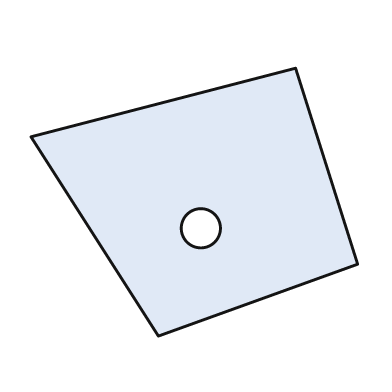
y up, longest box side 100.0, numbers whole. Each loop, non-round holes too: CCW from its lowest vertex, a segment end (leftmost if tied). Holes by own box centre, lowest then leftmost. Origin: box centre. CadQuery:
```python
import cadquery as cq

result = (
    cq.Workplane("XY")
    .moveTo(-11.0, -41.0)
    .lineTo(50.0, -19.0)
    .lineTo(31.0, 41.0)
    .lineTo(-50.0, 20.0)
    .close()
    .moveTo(2.0, -8.0)
    .circle(6.0)
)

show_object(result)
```